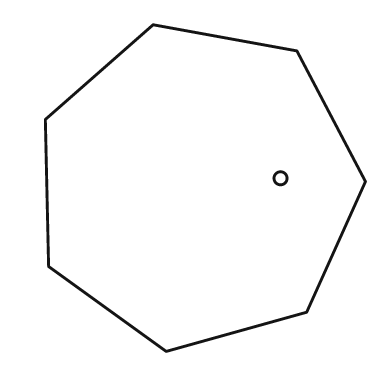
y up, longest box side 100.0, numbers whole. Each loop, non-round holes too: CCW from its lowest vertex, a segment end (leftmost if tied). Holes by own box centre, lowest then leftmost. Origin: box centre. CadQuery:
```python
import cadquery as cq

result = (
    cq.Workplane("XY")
    .moveTo(-12.0, -50.0)
    .lineTo(31.0, -38.0)
    .lineTo(49.0, 2.0)
    .lineTo(28.0, 42.0)
    .lineTo(-16.0, 50.0)
    .lineTo(-49.0, 21.0)
    .lineTo(-48.0, -24.0)
    .close()
    .moveTo(23.0, 3.0)
    .circle(2.0)
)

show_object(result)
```